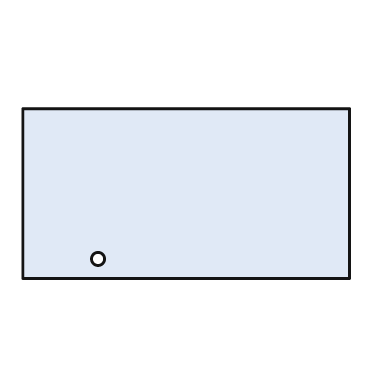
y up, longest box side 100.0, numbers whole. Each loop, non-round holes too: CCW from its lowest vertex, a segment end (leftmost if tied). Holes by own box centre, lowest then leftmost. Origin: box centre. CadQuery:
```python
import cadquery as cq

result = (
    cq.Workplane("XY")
    .moveTo(-50.0, -26.0)
    .lineTo(50.0, -26.0)
    .lineTo(50.0, 26.0)
    .lineTo(-50.0, 26.0)
    .close()
    .moveTo(-27.0, -20.0)
    .circle(2.0)
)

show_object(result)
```